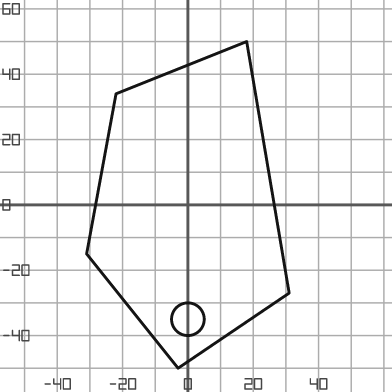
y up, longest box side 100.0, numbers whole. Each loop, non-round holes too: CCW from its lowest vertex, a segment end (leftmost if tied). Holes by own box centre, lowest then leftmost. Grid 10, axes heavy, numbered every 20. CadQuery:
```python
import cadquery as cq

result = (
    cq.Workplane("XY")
    .moveTo(-3.0, -50.0)
    .lineTo(31.0, -27.0)
    .lineTo(18.0, 50.0)
    .lineTo(-22.0, 34.0)
    .lineTo(-31.0, -15.0)
    .close()
    .moveTo(0.0, -35.0)
    .circle(5.0)
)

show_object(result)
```